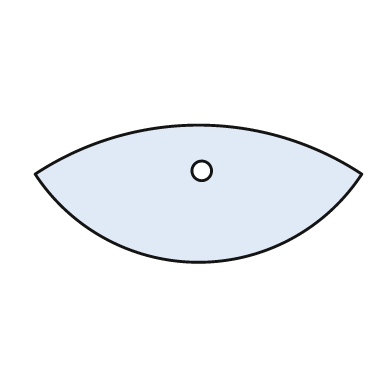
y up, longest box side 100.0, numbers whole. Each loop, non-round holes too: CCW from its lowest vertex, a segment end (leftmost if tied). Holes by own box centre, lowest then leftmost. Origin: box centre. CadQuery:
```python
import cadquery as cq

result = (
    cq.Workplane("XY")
    .moveTo(-50.0, 6.0)
    .threePointArc((0.0, -21.0), (50.0, 6.0))
    .threePointArc((0.0, 21.0), (-50.0, 6.0))
    .close()
    .moveTo(1.0, 7.0)
    .circle(3.0)
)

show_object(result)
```